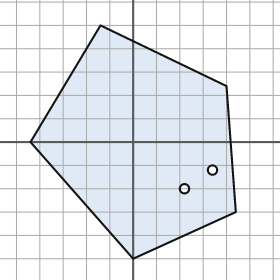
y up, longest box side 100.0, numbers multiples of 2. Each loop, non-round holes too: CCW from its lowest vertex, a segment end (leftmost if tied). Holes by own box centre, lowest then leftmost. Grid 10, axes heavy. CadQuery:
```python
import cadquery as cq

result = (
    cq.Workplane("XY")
    .moveTo(0.0, -50.0)
    .lineTo(44.0, -30.0)
    .lineTo(40.0, 24.0)
    .lineTo(-14.0, 50.0)
    .lineTo(-44.0, 0.0)
    .close()
    .moveTo(22.0, -20.0)
    .circle(2.0)
    .moveTo(34.0, -12.0)
    .circle(2.0)
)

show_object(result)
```